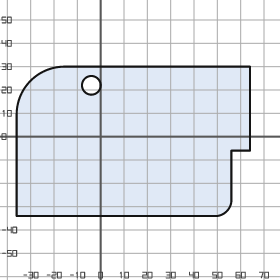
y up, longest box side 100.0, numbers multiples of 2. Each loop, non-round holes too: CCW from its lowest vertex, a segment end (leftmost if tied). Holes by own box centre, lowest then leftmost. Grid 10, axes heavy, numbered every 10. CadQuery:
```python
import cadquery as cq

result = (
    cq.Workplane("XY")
    .moveTo(-36.0, -34.0)
    .lineTo(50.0, -34.0)
    .threePointArc((54.0, -32.0), (56.0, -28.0))
    .lineTo(56.0, -6.0)
    .lineTo(64.0, -6.0)
    .lineTo(64.0, 30.0)
    .lineTo(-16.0, 30.0)
    .threePointArc((-30.0, 24.0), (-36.0, 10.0))
    .close()
    .moveTo(-4.0, 22.0)
    .circle(4.0)
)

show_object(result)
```